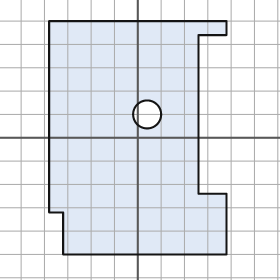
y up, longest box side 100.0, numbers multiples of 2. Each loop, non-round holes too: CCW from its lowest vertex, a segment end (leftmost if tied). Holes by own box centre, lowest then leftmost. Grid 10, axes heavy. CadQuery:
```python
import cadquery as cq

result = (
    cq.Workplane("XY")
    .moveTo(-32.0, -50.0)
    .lineTo(38.0, -50.0)
    .lineTo(38.0, -24.0)
    .lineTo(26.0, -24.0)
    .lineTo(26.0, 44.0)
    .lineTo(38.0, 44.0)
    .lineTo(38.0, 50.0)
    .lineTo(-38.0, 50.0)
    .lineTo(-38.0, -32.0)
    .lineTo(-32.0, -32.0)
    .close()
    .moveTo(4.0, 10.0)
    .circle(6.0)
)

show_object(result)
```